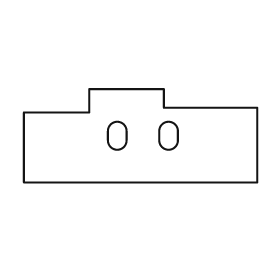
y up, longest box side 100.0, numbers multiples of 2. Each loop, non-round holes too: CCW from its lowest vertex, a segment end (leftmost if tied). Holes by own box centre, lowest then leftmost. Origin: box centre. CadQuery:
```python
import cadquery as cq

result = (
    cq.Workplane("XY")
    .moveTo(-50.0, -20.0)
    .lineTo(50.0, -20.0)
    .lineTo(50.0, 12.0)
    .lineTo(10.0, 12.0)
    .lineTo(10.0, 20.0)
    .lineTo(-22.0, 20.0)
    .lineTo(-22.0, 10.0)
    .lineTo(-50.0, 10.0)
    .close()
    .moveTo(-14.0, -2.0)
    .threePointArc((-10.0, -6.0), (-6.0, -2.0))
    .lineTo(-6.0, 2.0)
    .threePointArc((-10.0, 6.0), (-14.0, 2.0))
    .close()
    .moveTo(8.0, -2.0)
    .threePointArc((12.0, -6.0), (16.0, -2.0))
    .lineTo(16.0, 2.0)
    .threePointArc((12.0, 6.0), (8.0, 2.0))
    .close()
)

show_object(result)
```